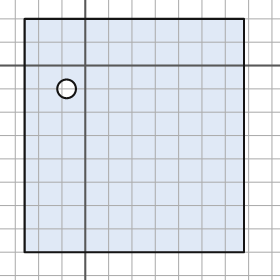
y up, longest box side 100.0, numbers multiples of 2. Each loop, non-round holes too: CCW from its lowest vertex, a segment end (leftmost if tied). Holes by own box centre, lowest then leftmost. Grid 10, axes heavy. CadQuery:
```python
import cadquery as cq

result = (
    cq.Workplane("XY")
    .moveTo(-26.0, -80.0)
    .lineTo(68.0, -80.0)
    .lineTo(68.0, 20.0)
    .lineTo(-26.0, 20.0)
    .close()
    .moveTo(-8.0, -10.0)
    .circle(4.0)
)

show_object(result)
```